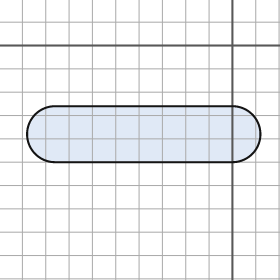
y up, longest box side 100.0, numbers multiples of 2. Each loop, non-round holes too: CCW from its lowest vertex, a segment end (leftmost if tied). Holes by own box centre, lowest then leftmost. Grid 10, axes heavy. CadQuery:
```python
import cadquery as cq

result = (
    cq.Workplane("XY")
    .moveTo(-76.0, -50.0)
    .lineTo(0.0, -50.0)
    .threePointArc((12.0, -38.0), (0.0, -26.0))
    .lineTo(-76.0, -26.0)
    .threePointArc((-88.0, -38.0), (-76.0, -50.0))
    .close()
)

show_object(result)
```